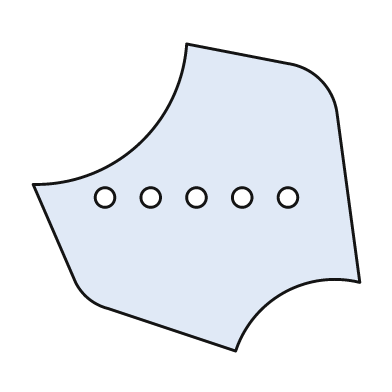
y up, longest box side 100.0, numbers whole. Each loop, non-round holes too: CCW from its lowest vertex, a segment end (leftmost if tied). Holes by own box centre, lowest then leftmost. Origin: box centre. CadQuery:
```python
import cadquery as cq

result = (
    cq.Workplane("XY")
    .moveTo(12.0, -47.0)
    .threePointArc((27.0, -29.0), (50.0, -26.0))
    .lineTo(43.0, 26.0)
    .threePointArc((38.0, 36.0), (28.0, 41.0))
    .lineTo(-3.0, 47.0)
    .threePointArc((-18.0, 16.0), (-50.0, 4.0))
    .lineTo(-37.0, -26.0)
    .threePointArc((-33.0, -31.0), (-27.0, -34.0))
    .close()
    .moveTo(-28.0, 0.0)
    .circle(3.0)
    .moveTo(-14.0, 0.0)
    .circle(3.0)
    .moveTo(0.0, 0.0)
    .circle(3.0)
    .moveTo(14.0, 0.0)
    .circle(3.0)
    .moveTo(28.0, 0.0)
    .circle(3.0)
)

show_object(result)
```